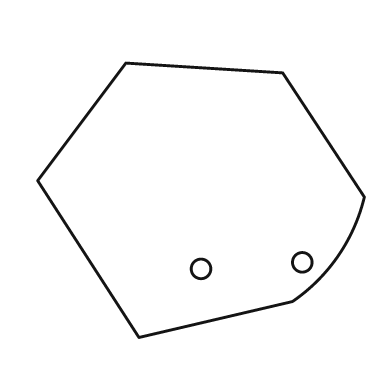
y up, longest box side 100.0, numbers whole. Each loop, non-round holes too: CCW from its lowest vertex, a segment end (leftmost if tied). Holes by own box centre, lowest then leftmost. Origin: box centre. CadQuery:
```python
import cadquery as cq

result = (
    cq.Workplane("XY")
    .moveTo(-19.0, -42.0)
    .lineTo(28.0, -31.0)
    .threePointArc((42.0, -17.0), (50.0, 1.0))
    .lineTo(25.0, 39.0)
    .lineTo(-23.0, 42.0)
    .lineTo(-50.0, 6.0)
    .close()
    .moveTo(0.0, -21.0)
    .circle(3.0)
    .moveTo(31.0, -19.0)
    .circle(3.0)
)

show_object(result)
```